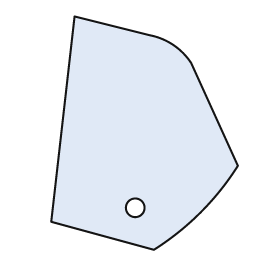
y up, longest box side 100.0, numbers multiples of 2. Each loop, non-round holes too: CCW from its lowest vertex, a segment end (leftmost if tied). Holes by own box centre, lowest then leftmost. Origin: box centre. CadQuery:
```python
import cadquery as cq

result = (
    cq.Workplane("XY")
    .moveTo(4.0, -50.0)
    .threePointArc((24.0, -34.0), (40.0, -14.0))
    .lineTo(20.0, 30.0)
    .threePointArc((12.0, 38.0), (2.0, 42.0))
    .lineTo(-30.0, 50.0)
    .lineTo(-40.0, -38.0)
    .close()
    .moveTo(-4.0, -32.0)
    .circle(4.0)
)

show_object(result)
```